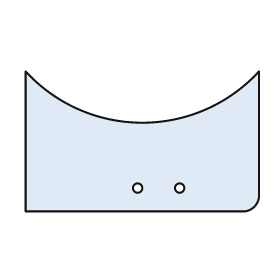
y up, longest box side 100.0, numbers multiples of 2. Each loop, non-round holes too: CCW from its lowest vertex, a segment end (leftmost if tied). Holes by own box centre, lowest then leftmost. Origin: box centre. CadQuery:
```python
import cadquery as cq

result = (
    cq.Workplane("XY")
    .moveTo(-50.0, -30.0)
    .lineTo(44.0, -30.0)
    .threePointArc((48.0, -28.0), (50.0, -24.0))
    .lineTo(50.0, 30.0)
    .threePointArc((0.0, 8.0), (-50.0, 30.0))
    .close()
    .moveTo(-2.0, -20.0)
    .circle(2.0)
    .moveTo(16.0, -20.0)
    .circle(2.0)
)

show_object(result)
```